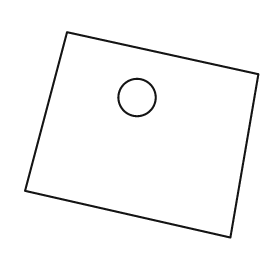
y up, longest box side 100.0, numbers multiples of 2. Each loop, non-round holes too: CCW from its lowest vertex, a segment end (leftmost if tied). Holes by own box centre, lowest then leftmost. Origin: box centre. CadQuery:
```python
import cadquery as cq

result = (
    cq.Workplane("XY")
    .moveTo(38.0, -44.0)
    .lineTo(50.0, 26.0)
    .lineTo(-32.0, 44.0)
    .lineTo(-50.0, -24.0)
    .close()
    .moveTo(-2.0, 16.0)
    .circle(8.0)
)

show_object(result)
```